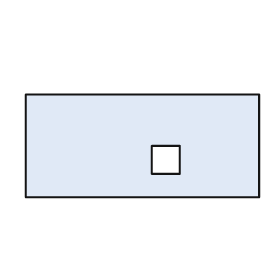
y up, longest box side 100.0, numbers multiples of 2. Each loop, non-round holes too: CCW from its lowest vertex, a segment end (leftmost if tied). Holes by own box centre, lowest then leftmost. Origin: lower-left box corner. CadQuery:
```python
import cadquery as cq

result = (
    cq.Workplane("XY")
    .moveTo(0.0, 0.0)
    .lineTo(100.0, 0.0)
    .lineTo(100.0, 44.0)
    .lineTo(0.0, 44.0)
    .close()
    .moveTo(54.0, 10.0)
    .lineTo(66.0, 10.0)
    .lineTo(66.0, 22.0)
    .lineTo(54.0, 22.0)
    .close()
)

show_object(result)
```